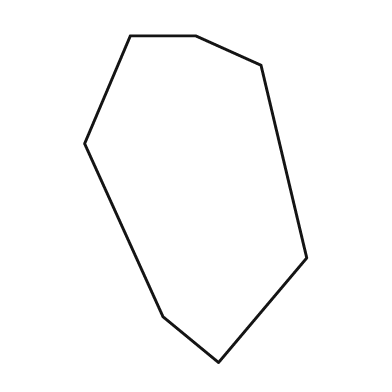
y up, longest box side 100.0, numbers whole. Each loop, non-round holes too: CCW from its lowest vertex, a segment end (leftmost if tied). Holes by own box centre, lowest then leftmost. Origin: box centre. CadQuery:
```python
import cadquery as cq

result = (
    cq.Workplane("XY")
    .moveTo(7.0, -50.0)
    .lineTo(34.0, -18.0)
    .lineTo(20.0, 41.0)
    .lineTo(0.0, 50.0)
    .lineTo(-20.0, 50.0)
    .lineTo(-34.0, 17.0)
    .lineTo(-10.0, -36.0)
    .close()
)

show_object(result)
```